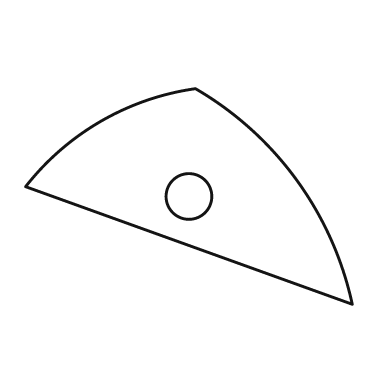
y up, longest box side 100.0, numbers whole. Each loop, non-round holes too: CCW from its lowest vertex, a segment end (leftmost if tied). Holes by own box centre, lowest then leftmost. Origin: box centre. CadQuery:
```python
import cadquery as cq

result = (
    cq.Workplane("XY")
    .moveTo(50.0, -33.0)
    .threePointArc((33.0, 5.0), (2.0, 33.0))
    .threePointArc((-27.0, 23.0), (-50.0, 3.0))
    .close()
    .moveTo(0.0, 0.0)
    .circle(7.0)
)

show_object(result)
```